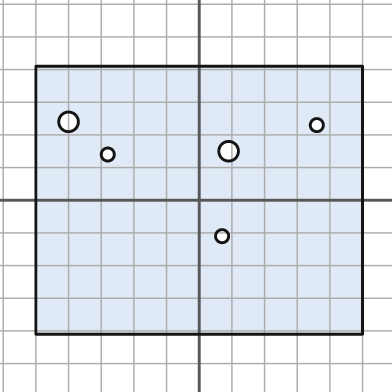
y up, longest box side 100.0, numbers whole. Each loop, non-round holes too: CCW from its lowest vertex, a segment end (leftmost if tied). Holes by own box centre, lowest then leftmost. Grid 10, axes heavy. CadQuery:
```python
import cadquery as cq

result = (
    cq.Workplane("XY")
    .moveTo(-50.0, -41.0)
    .lineTo(50.0, -41.0)
    .lineTo(50.0, 41.0)
    .lineTo(-50.0, 41.0)
    .close()
    .moveTo(7.0, -11.0)
    .circle(2.0)
    .moveTo(-28.0, 14.0)
    .circle(2.0)
    .moveTo(9.0, 15.0)
    .circle(3.0)
    .moveTo(36.0, 23.0)
    .circle(2.0)
    .moveTo(-40.0, 24.0)
    .circle(3.0)
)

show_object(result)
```